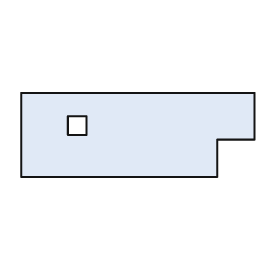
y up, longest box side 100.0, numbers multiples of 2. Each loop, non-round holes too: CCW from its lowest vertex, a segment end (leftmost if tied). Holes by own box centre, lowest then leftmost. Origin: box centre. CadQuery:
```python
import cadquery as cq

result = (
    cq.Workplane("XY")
    .moveTo(-50.0, -18.0)
    .lineTo(34.0, -18.0)
    .lineTo(34.0, -2.0)
    .lineTo(50.0, -2.0)
    .lineTo(50.0, 18.0)
    .lineTo(-50.0, 18.0)
    .close()
    .moveTo(-30.0, 0.0)
    .lineTo(-22.0, 0.0)
    .lineTo(-22.0, 8.0)
    .lineTo(-30.0, 8.0)
    .close()
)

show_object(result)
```